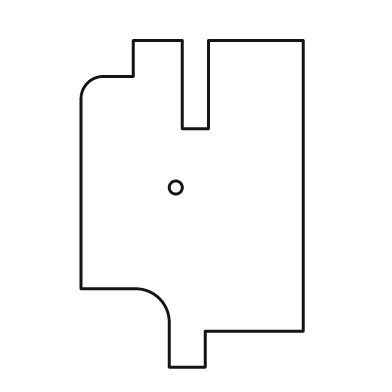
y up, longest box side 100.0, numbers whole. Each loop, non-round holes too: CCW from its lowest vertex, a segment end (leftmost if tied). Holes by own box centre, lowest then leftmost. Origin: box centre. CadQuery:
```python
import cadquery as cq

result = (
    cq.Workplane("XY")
    .moveTo(-7.0, -50.0)
    .lineTo(4.0, -50.0)
    .lineTo(4.0, -39.0)
    .lineTo(34.0, -39.0)
    .lineTo(34.0, 50.0)
    .lineTo(5.0, 50.0)
    .lineTo(5.0, 23.0)
    .lineTo(-3.0, 23.0)
    .lineTo(-3.0, 50.0)
    .lineTo(-18.0, 50.0)
    .lineTo(-18.0, 39.0)
    .lineTo(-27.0, 39.0)
    .threePointArc((-32.0, 37.0), (-34.0, 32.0))
    .lineTo(-34.0, -26.0)
    .lineTo(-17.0, -26.0)
    .threePointArc((-10.0, -29.0), (-7.0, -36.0))
    .close()
    .moveTo(-5.0, 5.0)
    .circle(2.0)
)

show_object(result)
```